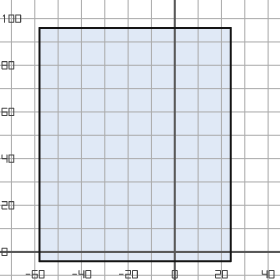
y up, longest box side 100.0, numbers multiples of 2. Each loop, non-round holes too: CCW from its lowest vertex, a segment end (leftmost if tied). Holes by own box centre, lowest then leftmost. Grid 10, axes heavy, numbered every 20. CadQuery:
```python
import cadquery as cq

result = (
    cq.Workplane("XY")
    .moveTo(-58.0, -4.0)
    .lineTo(24.0, -4.0)
    .lineTo(24.0, 96.0)
    .lineTo(-58.0, 96.0)
    .close()
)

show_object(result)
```